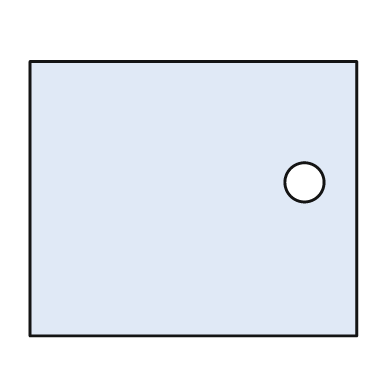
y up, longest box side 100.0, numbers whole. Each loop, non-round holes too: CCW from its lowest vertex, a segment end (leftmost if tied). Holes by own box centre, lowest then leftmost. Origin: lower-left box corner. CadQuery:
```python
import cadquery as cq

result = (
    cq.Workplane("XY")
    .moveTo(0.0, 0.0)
    .lineTo(100.0, 0.0)
    .lineTo(100.0, 84.0)
    .lineTo(0.0, 84.0)
    .close()
    .moveTo(84.0, 47.0)
    .circle(6.0)
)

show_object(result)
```